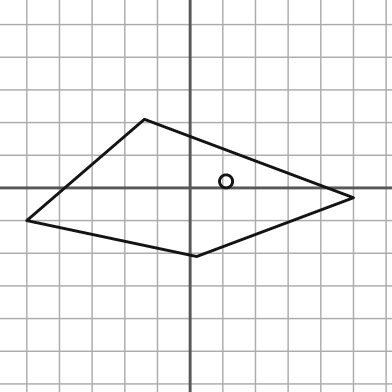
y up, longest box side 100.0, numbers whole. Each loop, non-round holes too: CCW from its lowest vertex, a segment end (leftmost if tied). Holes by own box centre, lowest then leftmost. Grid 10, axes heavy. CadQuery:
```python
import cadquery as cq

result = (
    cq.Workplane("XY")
    .moveTo(2.0, -21.0)
    .lineTo(50.0, -3.0)
    .lineTo(-14.0, 21.0)
    .lineTo(-50.0, -10.0)
    .close()
    .moveTo(11.0, 2.0)
    .circle(2.0)
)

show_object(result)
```